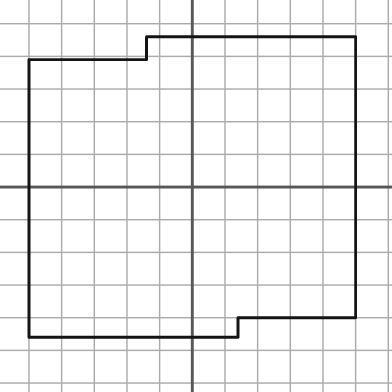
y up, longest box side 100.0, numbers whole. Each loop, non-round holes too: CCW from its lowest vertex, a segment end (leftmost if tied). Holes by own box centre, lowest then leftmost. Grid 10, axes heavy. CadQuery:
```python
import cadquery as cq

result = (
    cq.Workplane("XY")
    .moveTo(-50.0, -46.0)
    .lineTo(14.0, -46.0)
    .lineTo(14.0, -40.0)
    .lineTo(50.0, -40.0)
    .lineTo(50.0, 46.0)
    .lineTo(-14.0, 46.0)
    .lineTo(-14.0, 39.0)
    .lineTo(-50.0, 39.0)
    .close()
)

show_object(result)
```